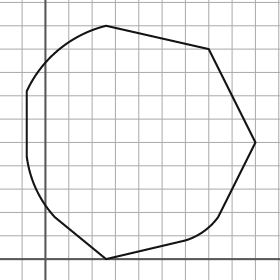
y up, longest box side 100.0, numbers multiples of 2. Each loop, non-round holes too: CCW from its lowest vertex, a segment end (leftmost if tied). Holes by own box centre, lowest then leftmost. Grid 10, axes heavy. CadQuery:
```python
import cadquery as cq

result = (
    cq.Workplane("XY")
    .moveTo(26.0, 0.0)
    .lineTo(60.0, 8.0)
    .threePointArc((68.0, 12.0), (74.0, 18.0))
    .lineTo(90.0, 50.0)
    .lineTo(70.0, 90.0)
    .lineTo(26.0, 100.0)
    .threePointArc((6.0, 90.0), (-8.0, 72.0))
    .lineTo(-8.0, 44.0)
    .threePointArc((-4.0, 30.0), (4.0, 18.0))
    .close()
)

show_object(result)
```